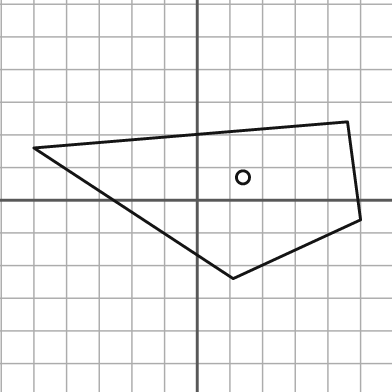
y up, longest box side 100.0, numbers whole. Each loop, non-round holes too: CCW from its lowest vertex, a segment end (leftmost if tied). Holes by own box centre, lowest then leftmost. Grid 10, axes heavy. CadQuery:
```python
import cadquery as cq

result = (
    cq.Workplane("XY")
    .moveTo(11.0, -24.0)
    .lineTo(50.0, -6.0)
    .lineTo(46.0, 24.0)
    .lineTo(-50.0, 16.0)
    .close()
    .moveTo(14.0, 7.0)
    .circle(2.0)
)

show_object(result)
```